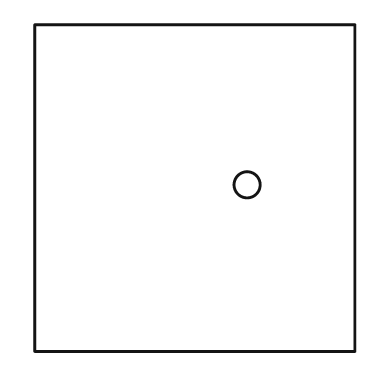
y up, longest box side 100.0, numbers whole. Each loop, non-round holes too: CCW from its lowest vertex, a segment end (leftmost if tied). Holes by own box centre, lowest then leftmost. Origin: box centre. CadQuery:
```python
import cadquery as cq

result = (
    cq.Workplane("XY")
    .moveTo(-49.0, -50.0)
    .lineTo(49.0, -50.0)
    .lineTo(49.0, 50.0)
    .lineTo(-49.0, 50.0)
    .close()
    .moveTo(16.0, 1.0)
    .circle(4.0)
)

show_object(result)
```